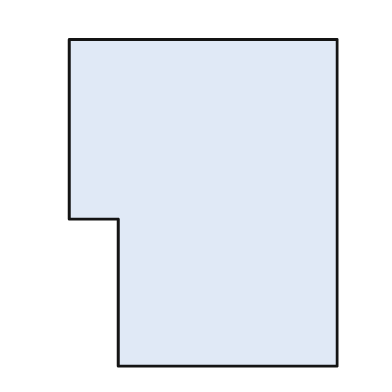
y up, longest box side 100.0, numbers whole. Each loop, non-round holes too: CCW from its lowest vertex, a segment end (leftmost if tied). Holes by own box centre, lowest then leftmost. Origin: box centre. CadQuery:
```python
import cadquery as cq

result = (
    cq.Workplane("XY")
    .moveTo(-26.0, -50.0)
    .lineTo(41.0, -50.0)
    .lineTo(41.0, 50.0)
    .lineTo(-41.0, 50.0)
    .lineTo(-41.0, -5.0)
    .lineTo(-26.0, -5.0)
    .close()
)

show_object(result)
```